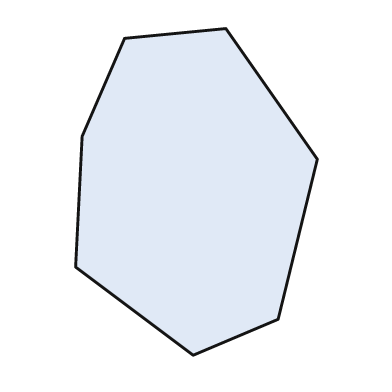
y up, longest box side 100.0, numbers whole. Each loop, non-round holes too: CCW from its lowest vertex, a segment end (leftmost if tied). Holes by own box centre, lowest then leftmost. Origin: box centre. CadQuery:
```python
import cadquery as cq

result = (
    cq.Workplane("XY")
    .moveTo(-1.0, -50.0)
    .lineTo(25.0, -39.0)
    .lineTo(37.0, 10.0)
    .lineTo(9.0, 50.0)
    .lineTo(-22.0, 47.0)
    .lineTo(-35.0, 17.0)
    .lineTo(-37.0, -23.0)
    .close()
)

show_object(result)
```